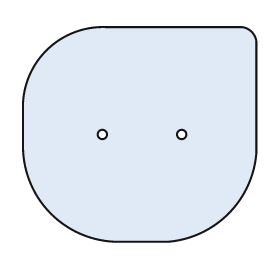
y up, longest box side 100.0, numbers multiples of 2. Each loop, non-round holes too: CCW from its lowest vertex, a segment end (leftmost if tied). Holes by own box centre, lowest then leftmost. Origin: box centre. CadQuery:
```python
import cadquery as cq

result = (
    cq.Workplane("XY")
    .moveTo(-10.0, -46.0)
    .lineTo(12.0, -46.0)
    .threePointArc((38.0, -34.0), (50.0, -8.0))
    .lineTo(50.0, 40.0)
    .threePointArc((48.0, 44.0), (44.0, 46.0))
    .lineTo(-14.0, 46.0)
    .threePointArc((-40.0, 36.0), (-50.0, 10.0))
    .lineTo(-50.0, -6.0)
    .threePointArc((-38.0, -34.0), (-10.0, -46.0))
    .close()
    .moveTo(-16.0, 0.0)
    .circle(2.0)
    .moveTo(18.0, 0.0)
    .circle(2.0)
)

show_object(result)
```